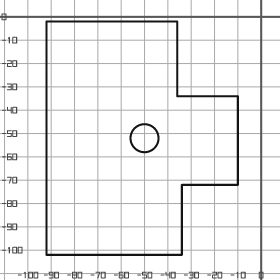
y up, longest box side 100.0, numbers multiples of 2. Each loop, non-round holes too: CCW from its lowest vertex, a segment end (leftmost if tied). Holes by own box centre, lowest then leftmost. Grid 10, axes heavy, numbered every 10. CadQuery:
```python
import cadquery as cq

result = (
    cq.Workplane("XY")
    .moveTo(-92.0, -102.0)
    .lineTo(-34.0, -102.0)
    .lineTo(-34.0, -72.0)
    .lineTo(-10.0, -72.0)
    .lineTo(-10.0, -34.0)
    .lineTo(-36.0, -34.0)
    .lineTo(-36.0, -2.0)
    .lineTo(-92.0, -2.0)
    .close()
    .moveTo(-50.0, -52.0)
    .circle(6.0)
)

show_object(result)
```